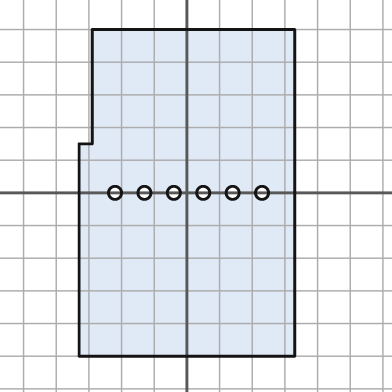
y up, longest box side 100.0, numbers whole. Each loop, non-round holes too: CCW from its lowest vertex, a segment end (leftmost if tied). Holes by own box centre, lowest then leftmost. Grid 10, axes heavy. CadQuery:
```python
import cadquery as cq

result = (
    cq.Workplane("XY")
    .moveTo(-33.0, -50.0)
    .lineTo(33.0, -50.0)
    .lineTo(33.0, 50.0)
    .lineTo(-29.0, 50.0)
    .lineTo(-29.0, 15.0)
    .lineTo(-33.0, 15.0)
    .close()
    .moveTo(-22.0, 0.0)
    .circle(2.0)
    .moveTo(-13.0, 0.0)
    .circle(2.0)
    .moveTo(-4.0, 0.0)
    .circle(2.0)
    .moveTo(5.0, 0.0)
    .circle(2.0)
    .moveTo(14.0, 0.0)
    .circle(2.0)
    .moveTo(23.0, 0.0)
    .circle(2.0)
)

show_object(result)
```